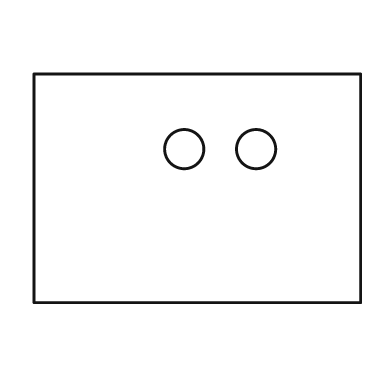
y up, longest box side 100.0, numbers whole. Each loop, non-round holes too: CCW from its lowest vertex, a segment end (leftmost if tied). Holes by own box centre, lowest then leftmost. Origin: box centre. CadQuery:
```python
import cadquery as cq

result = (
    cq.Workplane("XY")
    .moveTo(-50.0, -35.0)
    .lineTo(50.0, -35.0)
    .lineTo(50.0, 35.0)
    .lineTo(-50.0, 35.0)
    .close()
    .moveTo(-4.0, 12.0)
    .circle(6.0)
    .moveTo(18.0, 12.0)
    .circle(6.0)
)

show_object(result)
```